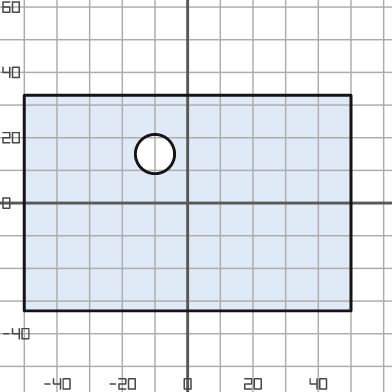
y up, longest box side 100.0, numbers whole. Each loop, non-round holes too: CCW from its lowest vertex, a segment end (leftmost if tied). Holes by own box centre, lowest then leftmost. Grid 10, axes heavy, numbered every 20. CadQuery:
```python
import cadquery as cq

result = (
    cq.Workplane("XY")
    .moveTo(-50.0, -33.0)
    .lineTo(50.0, -33.0)
    .lineTo(50.0, 33.0)
    .lineTo(-50.0, 33.0)
    .close()
    .moveTo(-10.0, 15.0)
    .circle(6.0)
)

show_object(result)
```